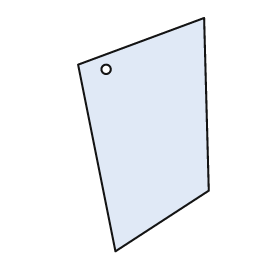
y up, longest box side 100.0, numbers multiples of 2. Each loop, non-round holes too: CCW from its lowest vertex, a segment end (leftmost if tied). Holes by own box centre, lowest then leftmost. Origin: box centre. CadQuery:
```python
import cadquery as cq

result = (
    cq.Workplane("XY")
    .moveTo(-12.0, -50.0)
    .lineTo(28.0, -24.0)
    .lineTo(26.0, 50.0)
    .lineTo(-28.0, 30.0)
    .close()
    .moveTo(-16.0, 28.0)
    .circle(2.0)
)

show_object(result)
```